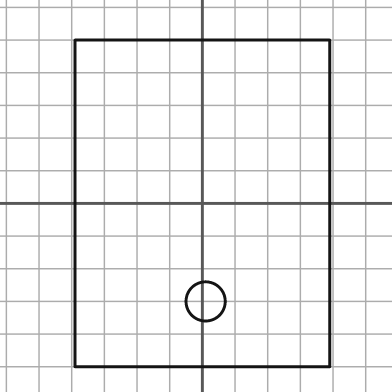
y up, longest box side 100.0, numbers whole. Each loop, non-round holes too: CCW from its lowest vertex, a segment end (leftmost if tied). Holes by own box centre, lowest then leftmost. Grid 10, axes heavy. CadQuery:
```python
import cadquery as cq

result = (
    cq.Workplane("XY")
    .moveTo(-39.0, -50.0)
    .lineTo(39.0, -50.0)
    .lineTo(39.0, 50.0)
    .lineTo(-39.0, 50.0)
    .close()
    .moveTo(1.0, -30.0)
    .circle(6.0)
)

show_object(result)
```